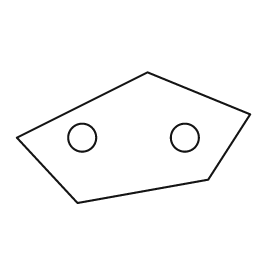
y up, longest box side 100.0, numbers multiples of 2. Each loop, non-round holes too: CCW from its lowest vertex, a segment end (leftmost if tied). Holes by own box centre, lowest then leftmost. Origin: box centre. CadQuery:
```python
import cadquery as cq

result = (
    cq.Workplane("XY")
    .moveTo(-24.0, -28.0)
    .lineTo(32.0, -18.0)
    .lineTo(50.0, 10.0)
    .lineTo(6.0, 28.0)
    .lineTo(-50.0, 0.0)
    .close()
    .moveTo(-22.0, 0.0)
    .circle(6.0)
    .moveTo(22.0, 0.0)
    .circle(6.0)
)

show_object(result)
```